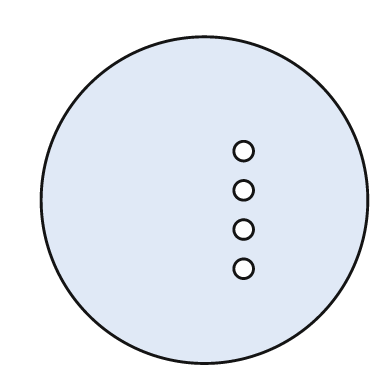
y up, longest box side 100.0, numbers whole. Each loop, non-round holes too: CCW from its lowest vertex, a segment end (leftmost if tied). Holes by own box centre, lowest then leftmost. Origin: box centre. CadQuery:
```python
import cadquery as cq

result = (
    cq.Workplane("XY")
    .moveTo(0.0, 0.0)
    .circle(50.0)
    .moveTo(12.0, -21.0)
    .circle(3.0)
    .moveTo(12.0, -9.0)
    .circle(3.0)
    .moveTo(12.0, 3.0)
    .circle(3.0)
    .moveTo(12.0, 15.0)
    .circle(3.0)
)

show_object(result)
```